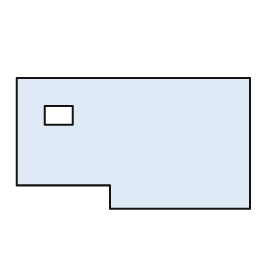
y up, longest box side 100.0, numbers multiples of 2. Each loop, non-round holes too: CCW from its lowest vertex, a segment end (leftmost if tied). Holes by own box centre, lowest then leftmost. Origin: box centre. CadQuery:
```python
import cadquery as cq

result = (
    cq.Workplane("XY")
    .moveTo(-10.0, -28.0)
    .lineTo(50.0, -28.0)
    .lineTo(50.0, 28.0)
    .lineTo(-50.0, 28.0)
    .lineTo(-50.0, -18.0)
    .lineTo(-10.0, -18.0)
    .close()
    .moveTo(-38.0, 8.0)
    .lineTo(-26.0, 8.0)
    .lineTo(-26.0, 16.0)
    .lineTo(-38.0, 16.0)
    .close()
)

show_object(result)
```